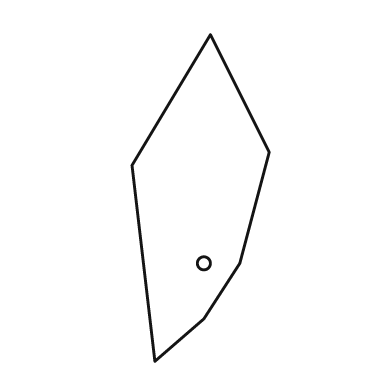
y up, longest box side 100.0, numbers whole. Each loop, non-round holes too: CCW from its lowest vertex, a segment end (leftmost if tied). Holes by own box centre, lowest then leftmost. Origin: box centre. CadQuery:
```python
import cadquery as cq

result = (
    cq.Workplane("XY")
    .moveTo(-14.0, -50.0)
    .lineTo(1.0, -37.0)
    .lineTo(12.0, -20.0)
    .lineTo(21.0, 14.0)
    .lineTo(3.0, 50.0)
    .lineTo(-21.0, 10.0)
    .close()
    .moveTo(1.0, -20.0)
    .circle(2.0)
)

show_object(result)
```